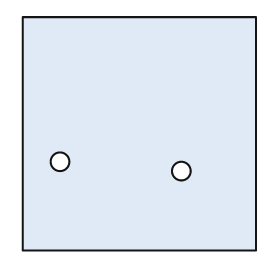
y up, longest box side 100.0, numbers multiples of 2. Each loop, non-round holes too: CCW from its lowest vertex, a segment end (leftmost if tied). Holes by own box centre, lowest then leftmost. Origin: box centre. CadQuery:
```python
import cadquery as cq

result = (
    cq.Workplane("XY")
    .moveTo(-50.0, -50.0)
    .lineTo(50.0, -50.0)
    .lineTo(50.0, 50.0)
    .lineTo(-50.0, 50.0)
    .close()
    .moveTo(18.0, -16.0)
    .circle(4.0)
    .moveTo(-34.0, -12.0)
    .circle(4.0)
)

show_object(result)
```